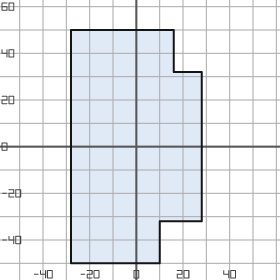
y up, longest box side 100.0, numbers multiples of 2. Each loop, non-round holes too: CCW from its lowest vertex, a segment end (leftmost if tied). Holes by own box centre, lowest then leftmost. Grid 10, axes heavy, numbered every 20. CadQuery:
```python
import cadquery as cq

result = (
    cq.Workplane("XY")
    .moveTo(-28.0, -50.0)
    .lineTo(10.0, -50.0)
    .lineTo(10.0, -32.0)
    .lineTo(28.0, -32.0)
    .lineTo(28.0, 32.0)
    .lineTo(16.0, 32.0)
    .lineTo(16.0, 50.0)
    .lineTo(-28.0, 50.0)
    .close()
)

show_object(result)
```